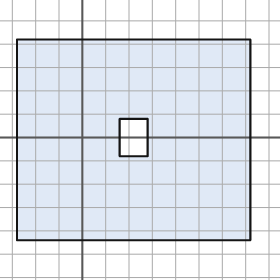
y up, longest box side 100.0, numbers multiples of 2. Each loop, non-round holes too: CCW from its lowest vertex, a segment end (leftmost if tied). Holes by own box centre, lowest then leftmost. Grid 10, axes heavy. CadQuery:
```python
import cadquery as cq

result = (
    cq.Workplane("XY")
    .moveTo(-28.0, -44.0)
    .lineTo(72.0, -44.0)
    .lineTo(72.0, 42.0)
    .lineTo(-28.0, 42.0)
    .close()
    .moveTo(16.0, -8.0)
    .lineTo(28.0, -8.0)
    .lineTo(28.0, 8.0)
    .lineTo(16.0, 8.0)
    .close()
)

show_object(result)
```